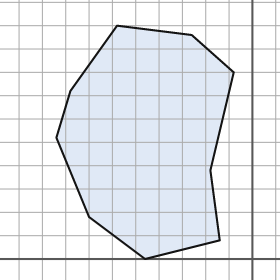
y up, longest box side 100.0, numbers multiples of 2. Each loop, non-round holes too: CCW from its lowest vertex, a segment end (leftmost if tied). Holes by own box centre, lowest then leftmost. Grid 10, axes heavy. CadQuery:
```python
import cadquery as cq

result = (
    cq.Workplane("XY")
    .moveTo(-46.0, 0.0)
    .lineTo(-14.0, 8.0)
    .lineTo(-18.0, 38.0)
    .lineTo(-8.0, 80.0)
    .lineTo(-26.0, 96.0)
    .lineTo(-58.0, 100.0)
    .lineTo(-78.0, 72.0)
    .lineTo(-84.0, 52.0)
    .lineTo(-70.0, 18.0)
    .close()
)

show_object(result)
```